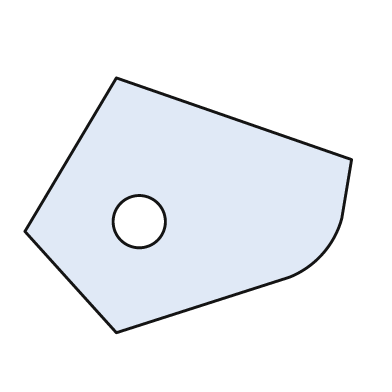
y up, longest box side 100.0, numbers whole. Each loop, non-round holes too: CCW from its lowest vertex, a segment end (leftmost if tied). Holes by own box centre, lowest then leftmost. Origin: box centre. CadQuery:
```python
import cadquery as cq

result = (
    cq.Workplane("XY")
    .moveTo(-22.0, -39.0)
    .lineTo(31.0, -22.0)
    .threePointArc((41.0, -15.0), (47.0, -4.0))
    .lineTo(50.0, 14.0)
    .lineTo(-22.0, 39.0)
    .lineTo(-50.0, -8.0)
    .close()
    .moveTo(-15.0, -5.0)
    .circle(8.0)
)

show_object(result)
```